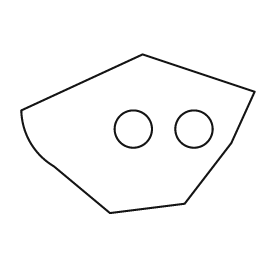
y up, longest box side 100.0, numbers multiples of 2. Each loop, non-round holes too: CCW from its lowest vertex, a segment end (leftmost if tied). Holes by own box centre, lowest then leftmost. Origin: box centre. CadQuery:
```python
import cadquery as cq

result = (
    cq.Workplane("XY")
    .moveTo(-12.0, -34.0)
    .lineTo(20.0, -30.0)
    .lineTo(40.0, -4.0)
    .lineTo(50.0, 18.0)
    .lineTo(2.0, 34.0)
    .lineTo(-50.0, 10.0)
    .threePointArc((-46.0, -4.0), (-36.0, -14.0))
    .close()
    .moveTo(-2.0, 2.0)
    .circle(8.0)
    .moveTo(24.0, 2.0)
    .circle(8.0)
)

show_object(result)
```